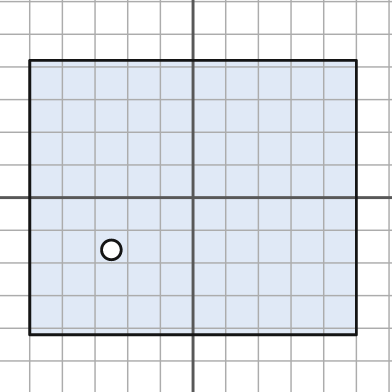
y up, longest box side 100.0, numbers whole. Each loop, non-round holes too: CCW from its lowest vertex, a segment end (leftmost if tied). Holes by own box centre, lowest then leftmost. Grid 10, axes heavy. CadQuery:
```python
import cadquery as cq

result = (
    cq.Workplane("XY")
    .moveTo(-50.0, -42.0)
    .lineTo(50.0, -42.0)
    .lineTo(50.0, 42.0)
    .lineTo(-50.0, 42.0)
    .close()
    .moveTo(-25.0, -16.0)
    .circle(3.0)
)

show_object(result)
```